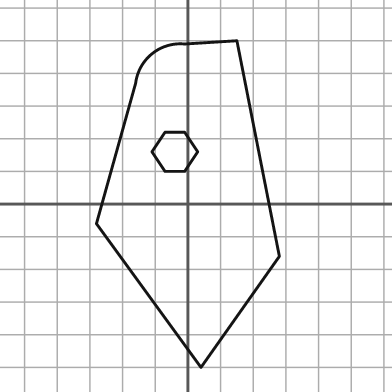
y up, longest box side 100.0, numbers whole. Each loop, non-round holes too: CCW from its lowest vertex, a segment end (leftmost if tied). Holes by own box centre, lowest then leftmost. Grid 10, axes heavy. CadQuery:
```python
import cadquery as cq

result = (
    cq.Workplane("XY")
    .moveTo(4.0, -50.0)
    .lineTo(28.0, -16.0)
    .lineTo(15.0, 50.0)
    .lineTo(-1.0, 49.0)
    .threePointArc((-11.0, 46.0), (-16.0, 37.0))
    .lineTo(-28.0, -6.0)
    .close()
    .moveTo(-7.0, 10.0)
    .lineTo(-1.0, 10.0)
    .lineTo(3.0, 16.0)
    .lineTo(-1.0, 22.0)
    .lineTo(-7.0, 22.0)
    .lineTo(-11.0, 16.0)
    .close()
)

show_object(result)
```